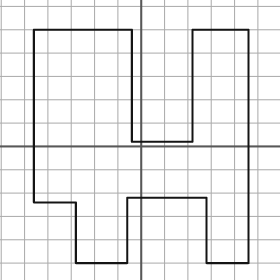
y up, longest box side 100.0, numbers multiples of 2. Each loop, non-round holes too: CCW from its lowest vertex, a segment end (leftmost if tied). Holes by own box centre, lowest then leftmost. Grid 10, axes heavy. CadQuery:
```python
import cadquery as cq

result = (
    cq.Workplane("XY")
    .moveTo(-28.0, -50.0)
    .lineTo(-6.0, -50.0)
    .lineTo(-6.0, -22.0)
    .lineTo(28.0, -22.0)
    .lineTo(28.0, -50.0)
    .lineTo(46.0, -50.0)
    .lineTo(46.0, 50.0)
    .lineTo(22.0, 50.0)
    .lineTo(22.0, 2.0)
    .lineTo(-4.0, 2.0)
    .lineTo(-4.0, 50.0)
    .lineTo(-46.0, 50.0)
    .lineTo(-46.0, -24.0)
    .lineTo(-28.0, -24.0)
    .close()
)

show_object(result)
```